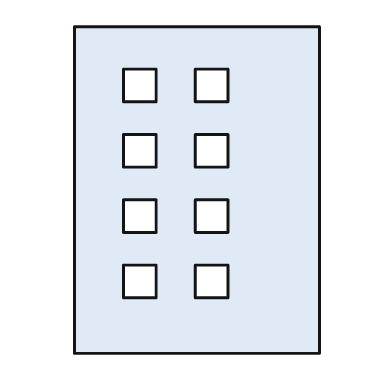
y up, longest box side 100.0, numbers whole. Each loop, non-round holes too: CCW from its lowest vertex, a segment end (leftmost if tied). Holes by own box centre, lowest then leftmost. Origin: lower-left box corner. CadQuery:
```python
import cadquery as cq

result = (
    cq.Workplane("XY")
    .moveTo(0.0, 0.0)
    .lineTo(75.0, 0.0)
    .lineTo(75.0, 100.0)
    .lineTo(0.0, 100.0)
    .close()
    .moveTo(15.0, 17.0)
    .lineTo(25.0, 17.0)
    .lineTo(25.0, 27.0)
    .lineTo(15.0, 27.0)
    .close()
    .moveTo(37.0, 17.0)
    .lineTo(47.0, 17.0)
    .lineTo(47.0, 27.0)
    .lineTo(37.0, 27.0)
    .close()
    .moveTo(15.0, 37.0)
    .lineTo(25.0, 37.0)
    .lineTo(25.0, 47.0)
    .lineTo(15.0, 47.0)
    .close()
    .moveTo(37.0, 37.0)
    .lineTo(47.0, 37.0)
    .lineTo(47.0, 47.0)
    .lineTo(37.0, 47.0)
    .close()
    .moveTo(15.0, 57.0)
    .lineTo(25.0, 57.0)
    .lineTo(25.0, 67.0)
    .lineTo(15.0, 67.0)
    .close()
    .moveTo(37.0, 57.0)
    .lineTo(47.0, 57.0)
    .lineTo(47.0, 67.0)
    .lineTo(37.0, 67.0)
    .close()
    .moveTo(15.0, 77.0)
    .lineTo(25.0, 77.0)
    .lineTo(25.0, 87.0)
    .lineTo(15.0, 87.0)
    .close()
    .moveTo(37.0, 77.0)
    .lineTo(47.0, 77.0)
    .lineTo(47.0, 87.0)
    .lineTo(37.0, 87.0)
    .close()
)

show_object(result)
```